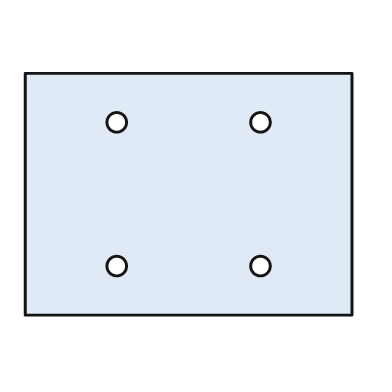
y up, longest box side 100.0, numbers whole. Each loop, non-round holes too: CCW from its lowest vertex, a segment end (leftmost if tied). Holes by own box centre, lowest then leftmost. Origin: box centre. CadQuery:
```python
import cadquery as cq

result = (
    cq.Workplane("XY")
    .moveTo(-50.0, -37.0)
    .lineTo(50.0, -37.0)
    .lineTo(50.0, 37.0)
    .lineTo(-50.0, 37.0)
    .close()
    .moveTo(-22.0, -22.0)
    .circle(3.0)
    .moveTo(22.0, -22.0)
    .circle(3.0)
    .moveTo(-22.0, 22.0)
    .circle(3.0)
    .moveTo(22.0, 22.0)
    .circle(3.0)
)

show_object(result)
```